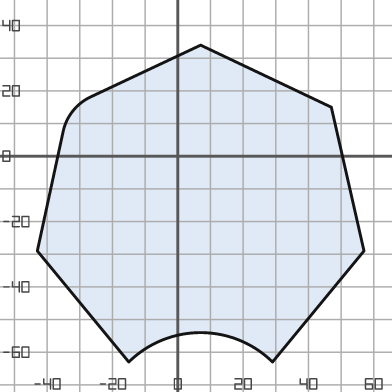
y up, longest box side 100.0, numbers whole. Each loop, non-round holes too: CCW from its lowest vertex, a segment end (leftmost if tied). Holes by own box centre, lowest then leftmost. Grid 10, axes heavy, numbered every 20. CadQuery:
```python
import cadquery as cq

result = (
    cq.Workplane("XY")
    .moveTo(-15.0, -63.0)
    .threePointArc((7.0, -54.0), (29.0, -63.0))
    .lineTo(57.0, -29.0)
    .lineTo(47.0, 15.0)
    .lineTo(7.0, 34.0)
    .lineTo(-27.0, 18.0)
    .threePointArc((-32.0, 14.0), (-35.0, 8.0))
    .lineTo(-43.0, -29.0)
    .close()
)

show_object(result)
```